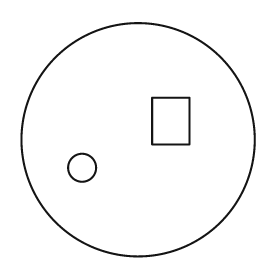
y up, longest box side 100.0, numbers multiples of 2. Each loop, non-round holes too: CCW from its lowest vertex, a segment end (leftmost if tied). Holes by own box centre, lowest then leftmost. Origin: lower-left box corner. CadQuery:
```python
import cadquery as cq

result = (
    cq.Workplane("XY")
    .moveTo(50.0, 50.0)
    .circle(50.0)
    .moveTo(26.0, 38.0)
    .circle(6.0)
    .moveTo(56.0, 48.0)
    .lineTo(72.0, 48.0)
    .lineTo(72.0, 68.0)
    .lineTo(56.0, 68.0)
    .close()
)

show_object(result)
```